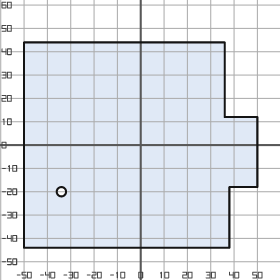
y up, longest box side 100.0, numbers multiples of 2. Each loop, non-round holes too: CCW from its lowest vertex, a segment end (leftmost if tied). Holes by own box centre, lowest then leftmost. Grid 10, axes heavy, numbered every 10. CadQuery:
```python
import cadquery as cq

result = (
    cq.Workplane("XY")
    .moveTo(-50.0, -44.0)
    .lineTo(38.0, -44.0)
    .lineTo(38.0, -18.0)
    .lineTo(50.0, -18.0)
    .lineTo(50.0, 12.0)
    .lineTo(36.0, 12.0)
    .lineTo(36.0, 44.0)
    .lineTo(-50.0, 44.0)
    .close()
    .moveTo(-34.0, -20.0)
    .circle(2.0)
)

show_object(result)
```